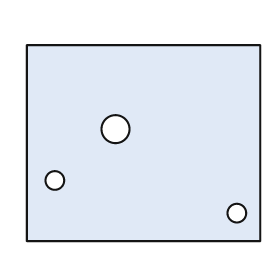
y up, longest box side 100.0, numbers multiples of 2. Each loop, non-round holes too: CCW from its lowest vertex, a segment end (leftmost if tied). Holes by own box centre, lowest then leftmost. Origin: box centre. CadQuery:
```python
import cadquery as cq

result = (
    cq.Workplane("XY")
    .moveTo(-50.0, -42.0)
    .lineTo(50.0, -42.0)
    .lineTo(50.0, 42.0)
    .lineTo(-50.0, 42.0)
    .close()
    .moveTo(40.0, -30.0)
    .circle(4.0)
    .moveTo(-38.0, -16.0)
    .circle(4.0)
    .moveTo(-12.0, 6.0)
    .circle(6.0)
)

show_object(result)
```